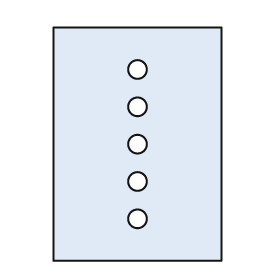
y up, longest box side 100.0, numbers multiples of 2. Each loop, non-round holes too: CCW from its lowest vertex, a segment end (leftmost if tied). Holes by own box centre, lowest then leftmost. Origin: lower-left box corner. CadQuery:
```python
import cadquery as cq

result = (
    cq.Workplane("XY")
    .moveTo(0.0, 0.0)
    .lineTo(72.0, 0.0)
    .lineTo(72.0, 100.0)
    .lineTo(0.0, 100.0)
    .close()
    .moveTo(36.0, 18.0)
    .circle(4.0)
    .moveTo(36.0, 34.0)
    .circle(4.0)
    .moveTo(36.0, 50.0)
    .circle(4.0)
    .moveTo(36.0, 66.0)
    .circle(4.0)
    .moveTo(36.0, 82.0)
    .circle(4.0)
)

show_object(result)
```